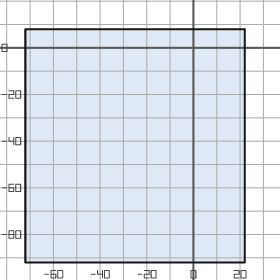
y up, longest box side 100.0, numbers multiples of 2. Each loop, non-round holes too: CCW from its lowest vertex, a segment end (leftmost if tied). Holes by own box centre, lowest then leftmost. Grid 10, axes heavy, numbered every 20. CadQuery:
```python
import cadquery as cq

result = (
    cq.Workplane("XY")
    .moveTo(-72.0, -92.0)
    .lineTo(22.0, -92.0)
    .lineTo(22.0, 8.0)
    .lineTo(-72.0, 8.0)
    .close()
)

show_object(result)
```